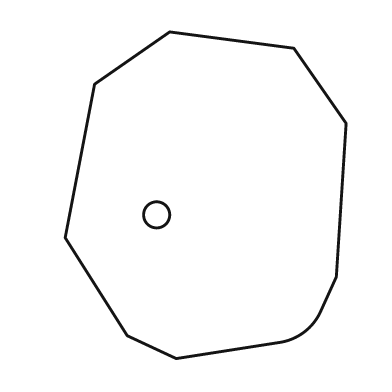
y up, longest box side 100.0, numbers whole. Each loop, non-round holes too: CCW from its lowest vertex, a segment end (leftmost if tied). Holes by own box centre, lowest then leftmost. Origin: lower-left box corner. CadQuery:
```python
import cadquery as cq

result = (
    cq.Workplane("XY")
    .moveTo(34.0, 0.0)
    .lineTo(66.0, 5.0)
    .threePointArc((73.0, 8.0), (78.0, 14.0))
    .lineTo(83.0, 25.0)
    .lineTo(86.0, 72.0)
    .lineTo(70.0, 95.0)
    .lineTo(32.0, 100.0)
    .lineTo(9.0, 84.0)
    .lineTo(0.0, 37.0)
    .lineTo(19.0, 7.0)
    .close()
    .moveTo(28.0, 44.0)
    .circle(4.0)
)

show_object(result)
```